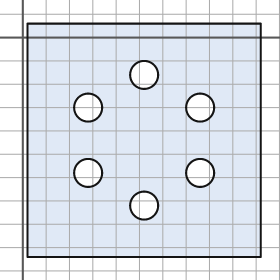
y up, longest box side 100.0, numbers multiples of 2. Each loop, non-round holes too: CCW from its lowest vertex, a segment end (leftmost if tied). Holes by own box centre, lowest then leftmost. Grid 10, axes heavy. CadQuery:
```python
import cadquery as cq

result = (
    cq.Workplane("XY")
    .moveTo(2.0, -94.0)
    .lineTo(102.0, -94.0)
    .lineTo(102.0, 6.0)
    .lineTo(2.0, 6.0)
    .close()
    .moveTo(52.0, -72.0)
    .circle(6.0)
    .moveTo(28.0, -58.0)
    .circle(6.0)
    .moveTo(76.0, -58.0)
    .circle(6.0)
    .moveTo(28.0, -30.0)
    .circle(6.0)
    .moveTo(76.0, -30.0)
    .circle(6.0)
    .moveTo(52.0, -16.0)
    .circle(6.0)
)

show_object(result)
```